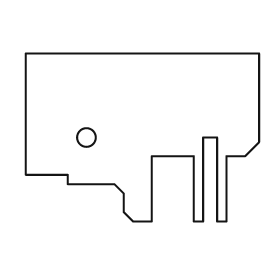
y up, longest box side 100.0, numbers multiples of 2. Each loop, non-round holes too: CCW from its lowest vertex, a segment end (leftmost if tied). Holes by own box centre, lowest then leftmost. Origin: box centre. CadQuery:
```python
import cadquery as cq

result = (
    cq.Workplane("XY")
    .moveTo(-4.0, -36.0)
    .lineTo(4.0, -36.0)
    .lineTo(4.0, -8.0)
    .lineTo(22.0, -8.0)
    .lineTo(22.0, -36.0)
    .lineTo(26.0, -36.0)
    .lineTo(26.0, 0.0)
    .lineTo(32.0, 0.0)
    .lineTo(32.0, -36.0)
    .lineTo(36.0, -36.0)
    .lineTo(36.0, -8.0)
    .lineTo(44.0, -8.0)
    .lineTo(50.0, -2.0)
    .lineTo(50.0, 36.0)
    .lineTo(-50.0, 36.0)
    .lineTo(-50.0, -16.0)
    .lineTo(-32.0, -16.0)
    .lineTo(-32.0, -20.0)
    .lineTo(-12.0, -20.0)
    .lineTo(-8.0, -24.0)
    .lineTo(-8.0, -32.0)
    .close()
    .moveTo(-24.0, 0.0)
    .circle(4.0)
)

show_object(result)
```